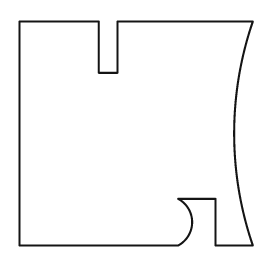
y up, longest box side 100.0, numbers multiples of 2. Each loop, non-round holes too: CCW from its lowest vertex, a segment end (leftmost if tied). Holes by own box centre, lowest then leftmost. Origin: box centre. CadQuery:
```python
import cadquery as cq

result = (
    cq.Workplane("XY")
    .moveTo(-50.0, -48.0)
    .lineTo(18.0, -48.0)
    .threePointArc((24.0, -38.0), (18.0, -28.0))
    .lineTo(34.0, -28.0)
    .lineTo(34.0, -48.0)
    .lineTo(50.0, -48.0)
    .threePointArc((42.0, 0.0), (50.0, 48.0))
    .lineTo(-8.0, 48.0)
    .lineTo(-8.0, 26.0)
    .lineTo(-16.0, 26.0)
    .lineTo(-16.0, 48.0)
    .lineTo(-50.0, 48.0)
    .close()
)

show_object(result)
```